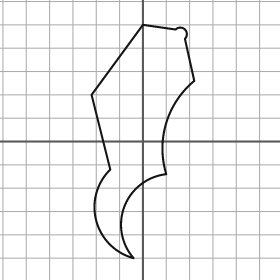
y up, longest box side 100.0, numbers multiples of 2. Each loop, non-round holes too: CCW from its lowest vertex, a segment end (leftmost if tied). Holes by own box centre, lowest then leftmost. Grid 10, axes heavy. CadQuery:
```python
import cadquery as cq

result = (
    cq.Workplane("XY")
    .moveTo(-4.0, -50.0)
    .threePointArc((-8.0, -28.0), (10.0, -14.0))
    .threePointArc((10.0, 8.0), (22.0, 26.0))
    .lineTo(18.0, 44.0)
    .threePointArc((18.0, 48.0), (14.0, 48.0))
    .lineTo(0.0, 50.0)
    .lineTo(-22.0, 20.0)
    .lineTo(-14.0, -12.0)
    .threePointArc((-20.0, -34.0), (-4.0, -50.0))
    .close()
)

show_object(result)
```